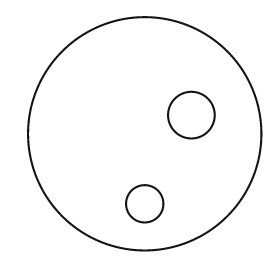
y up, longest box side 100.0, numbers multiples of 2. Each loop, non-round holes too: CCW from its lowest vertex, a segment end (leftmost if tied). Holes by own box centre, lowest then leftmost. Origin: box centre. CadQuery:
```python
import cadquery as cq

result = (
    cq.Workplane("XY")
    .moveTo(0.0, 0.0)
    .circle(50.0)
    .moveTo(0.0, -30.0)
    .circle(8.0)
    .moveTo(20.0, 8.0)
    .circle(10.0)
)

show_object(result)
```